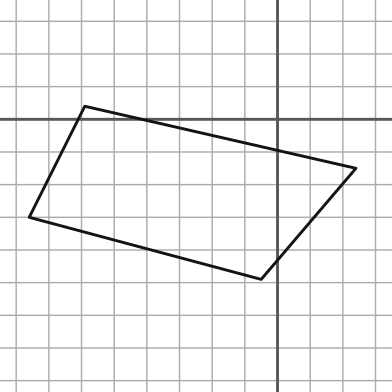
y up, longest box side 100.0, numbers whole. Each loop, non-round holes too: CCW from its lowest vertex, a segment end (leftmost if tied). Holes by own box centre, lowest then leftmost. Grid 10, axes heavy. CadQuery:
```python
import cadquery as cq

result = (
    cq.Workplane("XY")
    .moveTo(-5.0, -49.0)
    .lineTo(24.0, -15.0)
    .lineTo(-59.0, 4.0)
    .lineTo(-76.0, -30.0)
    .close()
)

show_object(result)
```